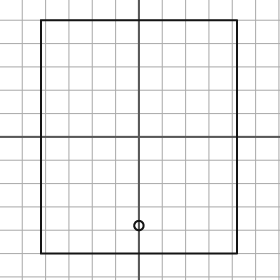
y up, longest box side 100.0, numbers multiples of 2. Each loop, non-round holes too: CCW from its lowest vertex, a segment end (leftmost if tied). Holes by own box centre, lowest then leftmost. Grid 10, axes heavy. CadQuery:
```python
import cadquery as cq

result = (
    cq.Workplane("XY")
    .moveTo(-42.0, -50.0)
    .lineTo(42.0, -50.0)
    .lineTo(42.0, 50.0)
    .lineTo(-42.0, 50.0)
    .close()
    .moveTo(0.0, -38.0)
    .circle(2.0)
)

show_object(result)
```